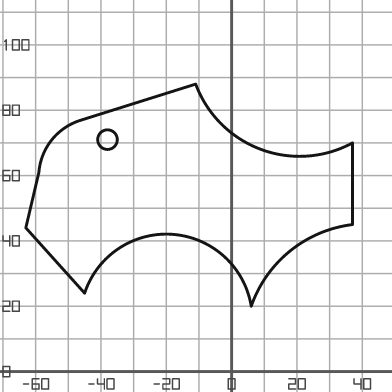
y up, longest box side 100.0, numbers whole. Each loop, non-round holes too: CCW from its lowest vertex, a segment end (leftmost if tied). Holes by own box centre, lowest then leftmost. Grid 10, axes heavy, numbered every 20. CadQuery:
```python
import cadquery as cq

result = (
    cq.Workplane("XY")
    .moveTo(6.0, 20.0)
    .threePointArc((18.0, 37.0), (37.0, 45.0))
    .lineTo(37.0, 70.0)
    .threePointArc((9.0, 68.0), (-11.0, 88.0))
    .lineTo(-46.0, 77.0)
    .threePointArc((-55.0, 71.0), (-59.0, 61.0))
    .lineTo(-63.0, 44.0)
    .lineTo(-45.0, 24.0)
    .threePointArc((-18.0, 42.0), (6.0, 20.0))
    .close()
    .moveTo(-38.0, 71.0)
    .circle(3.0)
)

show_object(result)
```